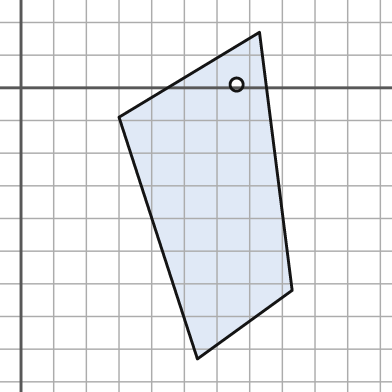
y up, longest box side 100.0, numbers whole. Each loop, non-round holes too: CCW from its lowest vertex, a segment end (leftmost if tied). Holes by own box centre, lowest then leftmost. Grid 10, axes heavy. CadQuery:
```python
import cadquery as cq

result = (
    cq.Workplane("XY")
    .moveTo(54.0, -83.0)
    .lineTo(83.0, -62.0)
    .lineTo(73.0, 17.0)
    .lineTo(30.0, -9.0)
    .close()
    .moveTo(66.0, 1.0)
    .circle(2.0)
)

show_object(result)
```